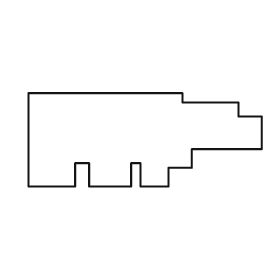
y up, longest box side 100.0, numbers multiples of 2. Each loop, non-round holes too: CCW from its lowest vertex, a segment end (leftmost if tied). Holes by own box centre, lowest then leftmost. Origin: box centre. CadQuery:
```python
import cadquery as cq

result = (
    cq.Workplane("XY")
    .moveTo(-50.0, -20.0)
    .lineTo(-30.0, -20.0)
    .lineTo(-30.0, -10.0)
    .lineTo(-24.0, -10.0)
    .lineTo(-24.0, -20.0)
    .lineTo(-6.0, -20.0)
    .lineTo(-6.0, -10.0)
    .lineTo(-2.0, -10.0)
    .lineTo(-2.0, -20.0)
    .lineTo(10.0, -20.0)
    .lineTo(10.0, -12.0)
    .lineTo(20.0, -12.0)
    .lineTo(20.0, -4.0)
    .lineTo(50.0, -4.0)
    .lineTo(50.0, 10.0)
    .lineTo(40.0, 10.0)
    .lineTo(40.0, 16.0)
    .lineTo(16.0, 16.0)
    .lineTo(16.0, 20.0)
    .lineTo(-50.0, 20.0)
    .close()
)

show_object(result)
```